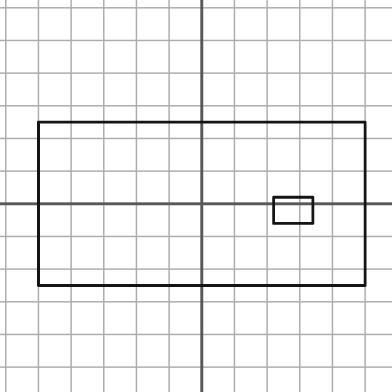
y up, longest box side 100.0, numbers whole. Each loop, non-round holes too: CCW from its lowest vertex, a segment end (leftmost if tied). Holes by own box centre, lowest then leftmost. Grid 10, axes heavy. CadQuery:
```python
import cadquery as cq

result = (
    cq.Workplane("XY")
    .moveTo(-50.0, -25.0)
    .lineTo(50.0, -25.0)
    .lineTo(50.0, 25.0)
    .lineTo(-50.0, 25.0)
    .close()
    .moveTo(22.0, -6.0)
    .lineTo(34.0, -6.0)
    .lineTo(34.0, 2.0)
    .lineTo(22.0, 2.0)
    .close()
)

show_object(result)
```